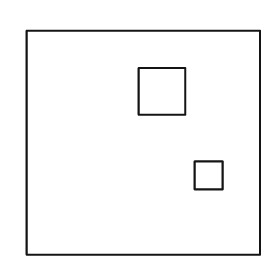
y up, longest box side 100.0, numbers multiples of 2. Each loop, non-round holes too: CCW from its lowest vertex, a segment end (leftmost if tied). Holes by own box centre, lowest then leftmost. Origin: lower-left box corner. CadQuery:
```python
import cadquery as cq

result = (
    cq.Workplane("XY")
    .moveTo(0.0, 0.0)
    .lineTo(100.0, 0.0)
    .lineTo(100.0, 96.0)
    .lineTo(0.0, 96.0)
    .close()
    .moveTo(72.0, 28.0)
    .lineTo(84.0, 28.0)
    .lineTo(84.0, 40.0)
    .lineTo(72.0, 40.0)
    .close()
    .moveTo(48.0, 60.0)
    .lineTo(68.0, 60.0)
    .lineTo(68.0, 80.0)
    .lineTo(48.0, 80.0)
    .close()
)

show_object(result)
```